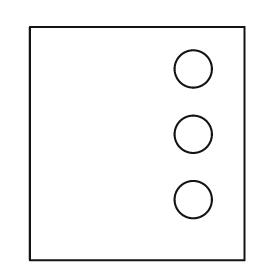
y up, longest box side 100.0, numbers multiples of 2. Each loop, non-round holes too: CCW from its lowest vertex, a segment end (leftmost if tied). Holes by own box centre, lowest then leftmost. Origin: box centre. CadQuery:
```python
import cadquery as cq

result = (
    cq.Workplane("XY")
    .moveTo(-46.0, -50.0)
    .lineTo(46.0, -50.0)
    .lineTo(46.0, 50.0)
    .lineTo(-46.0, 50.0)
    .close()
    .moveTo(24.0, -24.0)
    .circle(8.0)
    .moveTo(24.0, 4.0)
    .circle(8.0)
    .moveTo(24.0, 32.0)
    .circle(8.0)
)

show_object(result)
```